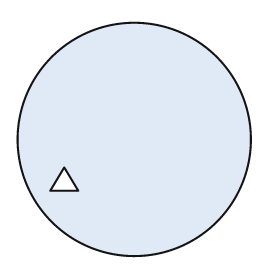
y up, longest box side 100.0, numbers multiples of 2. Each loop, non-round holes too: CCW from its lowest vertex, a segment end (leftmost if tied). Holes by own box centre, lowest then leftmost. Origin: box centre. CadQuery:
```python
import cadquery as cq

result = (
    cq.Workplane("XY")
    .moveTo(0.0, 0.0)
    .circle(50.0)
    .moveTo(-36.0, -22.0)
    .lineTo(-24.0, -22.0)
    .lineTo(-30.0, -12.0)
    .close()
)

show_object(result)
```